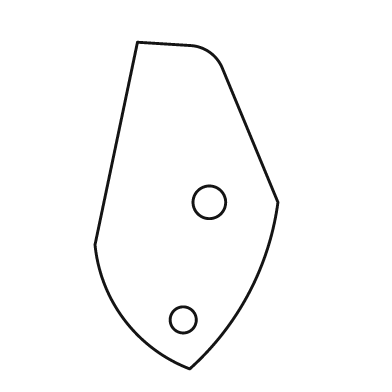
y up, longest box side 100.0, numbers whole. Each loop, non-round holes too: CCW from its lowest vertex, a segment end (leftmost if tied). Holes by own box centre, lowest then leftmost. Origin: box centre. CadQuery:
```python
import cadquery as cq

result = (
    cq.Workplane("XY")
    .moveTo(1.0, -50.0)
    .threePointArc((19.0, -27.0), (28.0, 1.0))
    .lineTo(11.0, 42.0)
    .threePointArc((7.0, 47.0), (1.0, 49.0))
    .lineTo(-15.0, 50.0)
    .lineTo(-28.0, -12.0)
    .threePointArc((-19.0, -35.0), (1.0, -50.0))
    .close()
    .moveTo(-1.0, -35.0)
    .circle(4.0)
    .moveTo(7.0, 1.0)
    .circle(5.0)
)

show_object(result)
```